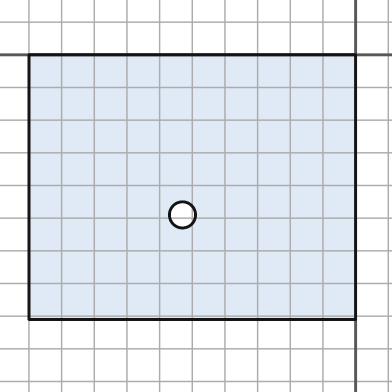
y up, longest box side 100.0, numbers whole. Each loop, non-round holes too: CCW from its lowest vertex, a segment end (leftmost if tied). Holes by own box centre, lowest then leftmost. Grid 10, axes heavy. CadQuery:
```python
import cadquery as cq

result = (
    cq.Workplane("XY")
    .moveTo(-100.0, -81.0)
    .lineTo(0.0, -81.0)
    .lineTo(0.0, 0.0)
    .lineTo(-100.0, 0.0)
    .close()
    .moveTo(-53.0, -49.0)
    .circle(4.0)
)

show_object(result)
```